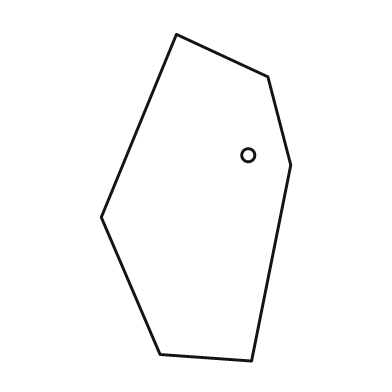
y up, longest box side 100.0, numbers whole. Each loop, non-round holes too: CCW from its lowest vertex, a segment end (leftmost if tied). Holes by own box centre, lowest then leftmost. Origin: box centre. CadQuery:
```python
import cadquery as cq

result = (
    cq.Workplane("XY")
    .moveTo(17.0, -50.0)
    .lineTo(29.0, 10.0)
    .lineTo(22.0, 37.0)
    .lineTo(-6.0, 50.0)
    .lineTo(-29.0, -6.0)
    .lineTo(-11.0, -48.0)
    .close()
    .moveTo(16.0, 13.0)
    .circle(2.0)
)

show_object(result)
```